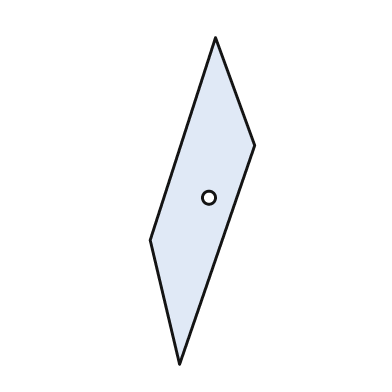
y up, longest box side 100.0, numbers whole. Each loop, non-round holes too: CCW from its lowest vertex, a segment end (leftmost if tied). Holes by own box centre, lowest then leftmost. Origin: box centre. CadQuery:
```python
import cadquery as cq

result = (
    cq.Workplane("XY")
    .moveTo(-7.0, -50.0)
    .lineTo(16.0, 17.0)
    .lineTo(4.0, 50.0)
    .lineTo(-16.0, -12.0)
    .close()
    .moveTo(2.0, 1.0)
    .circle(2.0)
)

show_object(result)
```